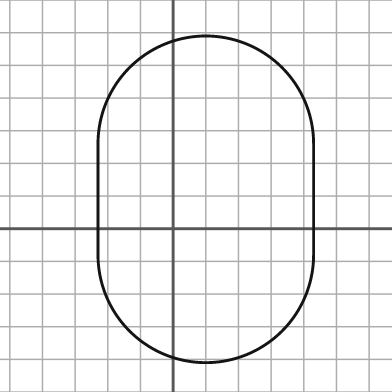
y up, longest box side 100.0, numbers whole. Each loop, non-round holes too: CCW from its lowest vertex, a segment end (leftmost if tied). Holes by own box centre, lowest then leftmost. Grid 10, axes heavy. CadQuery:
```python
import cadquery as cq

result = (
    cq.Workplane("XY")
    .moveTo(-23.0, -8.0)
    .threePointArc((10.0, -41.0), (43.0, -8.0))
    .lineTo(43.0, 26.0)
    .threePointArc((10.0, 59.0), (-23.0, 26.0))
    .close()
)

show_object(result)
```